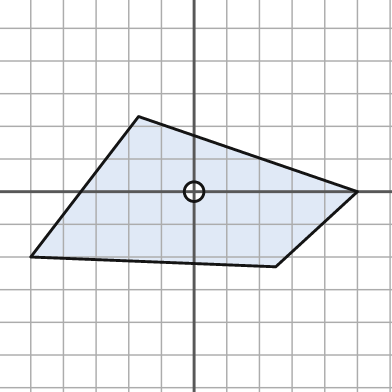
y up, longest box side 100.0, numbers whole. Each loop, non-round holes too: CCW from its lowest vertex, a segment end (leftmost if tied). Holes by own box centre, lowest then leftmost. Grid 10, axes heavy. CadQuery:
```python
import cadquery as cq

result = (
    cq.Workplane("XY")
    .moveTo(25.0, -23.0)
    .lineTo(50.0, 0.0)
    .lineTo(-17.0, 23.0)
    .lineTo(-50.0, -20.0)
    .close()
    .moveTo(0.0, 0.0)
    .circle(3.0)
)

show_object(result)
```